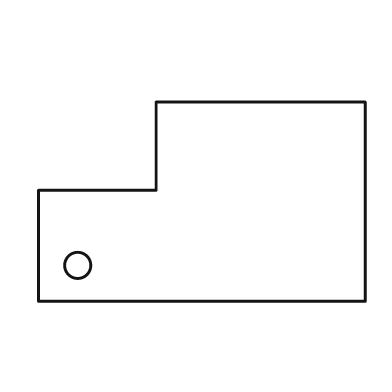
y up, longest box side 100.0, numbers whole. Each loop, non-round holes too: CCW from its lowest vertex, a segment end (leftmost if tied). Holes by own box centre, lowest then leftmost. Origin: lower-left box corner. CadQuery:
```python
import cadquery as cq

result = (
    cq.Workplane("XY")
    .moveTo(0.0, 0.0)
    .lineTo(100.0, 0.0)
    .lineTo(100.0, 61.0)
    .lineTo(36.0, 61.0)
    .lineTo(36.0, 34.0)
    .lineTo(0.0, 34.0)
    .close()
    .moveTo(12.0, 11.0)
    .circle(4.0)
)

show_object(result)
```